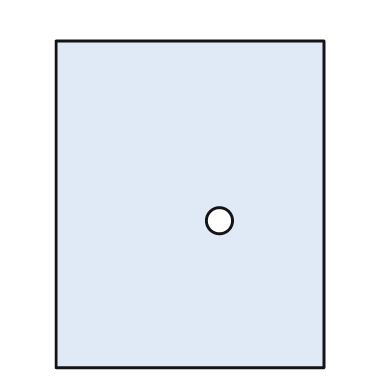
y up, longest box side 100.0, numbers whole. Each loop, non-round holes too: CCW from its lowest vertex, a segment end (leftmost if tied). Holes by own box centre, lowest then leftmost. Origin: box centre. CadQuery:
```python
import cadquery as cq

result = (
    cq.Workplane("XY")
    .moveTo(-41.0, -50.0)
    .lineTo(41.0, -50.0)
    .lineTo(41.0, 50.0)
    .lineTo(-41.0, 50.0)
    .close()
    .moveTo(9.0, -5.0)
    .circle(4.0)
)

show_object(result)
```